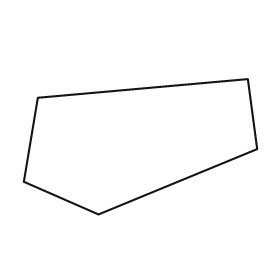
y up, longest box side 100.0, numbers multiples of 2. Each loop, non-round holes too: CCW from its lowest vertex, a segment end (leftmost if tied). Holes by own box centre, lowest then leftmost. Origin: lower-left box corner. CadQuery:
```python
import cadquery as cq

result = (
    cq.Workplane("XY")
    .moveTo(32.0, 0.0)
    .lineTo(100.0, 28.0)
    .lineTo(96.0, 58.0)
    .lineTo(6.0, 50.0)
    .lineTo(0.0, 14.0)
    .close()
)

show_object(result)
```